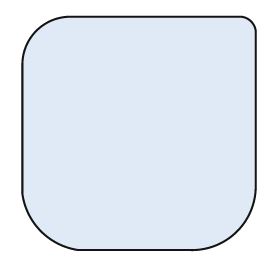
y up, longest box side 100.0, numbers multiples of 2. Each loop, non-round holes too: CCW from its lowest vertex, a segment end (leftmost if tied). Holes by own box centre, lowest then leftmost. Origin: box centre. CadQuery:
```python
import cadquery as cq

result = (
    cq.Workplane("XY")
    .moveTo(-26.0, -50.0)
    .lineTo(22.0, -50.0)
    .threePointArc((42.0, -42.0), (50.0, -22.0))
    .lineTo(50.0, 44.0)
    .threePointArc((48.0, 48.0), (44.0, 50.0))
    .lineTo(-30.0, 50.0)
    .threePointArc((-44.0, 44.0), (-50.0, 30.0))
    .lineTo(-50.0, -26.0)
    .threePointArc((-42.0, -42.0), (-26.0, -50.0))
    .close()
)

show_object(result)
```